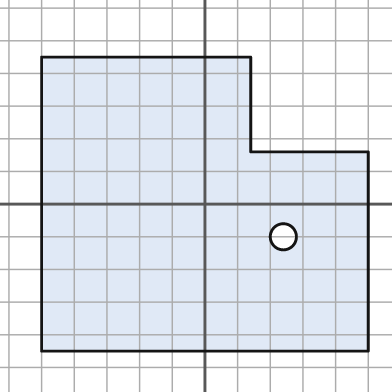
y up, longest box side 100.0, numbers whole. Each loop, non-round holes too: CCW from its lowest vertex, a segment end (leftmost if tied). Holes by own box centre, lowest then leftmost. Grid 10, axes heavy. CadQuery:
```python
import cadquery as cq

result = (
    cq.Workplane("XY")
    .moveTo(-50.0, -45.0)
    .lineTo(50.0, -45.0)
    .lineTo(50.0, 16.0)
    .lineTo(14.0, 16.0)
    .lineTo(14.0, 45.0)
    .lineTo(-50.0, 45.0)
    .close()
    .moveTo(24.0, -10.0)
    .circle(4.0)
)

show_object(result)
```